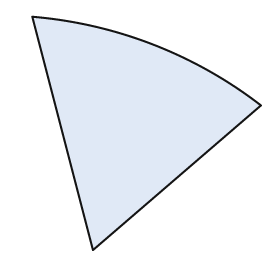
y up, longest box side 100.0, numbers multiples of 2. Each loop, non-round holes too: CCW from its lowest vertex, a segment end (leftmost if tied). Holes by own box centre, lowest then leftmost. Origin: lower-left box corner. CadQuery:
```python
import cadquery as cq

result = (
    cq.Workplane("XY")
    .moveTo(26.0, 0.0)
    .lineTo(98.0, 62.0)
    .threePointArc((52.0, 88.0), (0.0, 100.0))
    .close()
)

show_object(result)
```